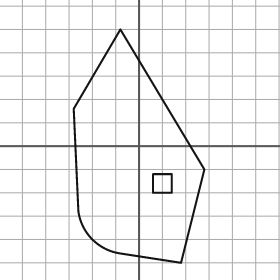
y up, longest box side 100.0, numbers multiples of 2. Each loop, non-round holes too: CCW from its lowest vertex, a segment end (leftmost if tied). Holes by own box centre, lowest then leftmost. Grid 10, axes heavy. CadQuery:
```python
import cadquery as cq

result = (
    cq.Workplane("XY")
    .moveTo(18.0, -50.0)
    .lineTo(28.0, -10.0)
    .lineTo(-8.0, 50.0)
    .lineTo(-28.0, 16.0)
    .lineTo(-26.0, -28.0)
    .threePointArc((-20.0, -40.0), (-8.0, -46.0))
    .close()
    .moveTo(6.0, -20.0)
    .lineTo(14.0, -20.0)
    .lineTo(14.0, -12.0)
    .lineTo(6.0, -12.0)
    .close()
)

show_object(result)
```